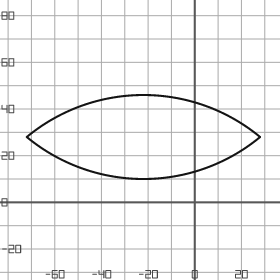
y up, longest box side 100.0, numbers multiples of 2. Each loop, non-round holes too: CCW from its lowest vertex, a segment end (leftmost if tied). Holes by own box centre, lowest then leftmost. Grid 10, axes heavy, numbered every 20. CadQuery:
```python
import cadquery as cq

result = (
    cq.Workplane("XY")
    .moveTo(-72.0, 28.0)
    .threePointArc((-22.0, 10.0), (28.0, 28.0))
    .threePointArc((-22.0, 46.0), (-72.0, 28.0))
    .close()
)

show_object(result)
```